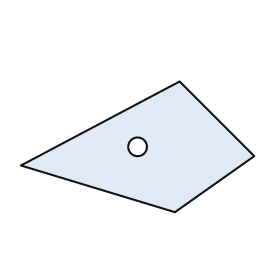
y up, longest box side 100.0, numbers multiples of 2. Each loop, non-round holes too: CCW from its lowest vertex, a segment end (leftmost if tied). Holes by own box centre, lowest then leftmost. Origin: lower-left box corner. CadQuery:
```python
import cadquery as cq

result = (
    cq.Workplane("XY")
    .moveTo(66.0, 0.0)
    .lineTo(100.0, 24.0)
    .lineTo(68.0, 56.0)
    .lineTo(0.0, 20.0)
    .close()
    .moveTo(50.0, 28.0)
    .circle(4.0)
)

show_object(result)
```